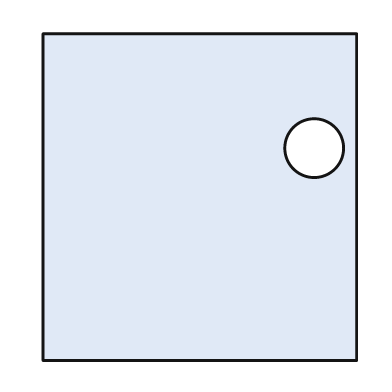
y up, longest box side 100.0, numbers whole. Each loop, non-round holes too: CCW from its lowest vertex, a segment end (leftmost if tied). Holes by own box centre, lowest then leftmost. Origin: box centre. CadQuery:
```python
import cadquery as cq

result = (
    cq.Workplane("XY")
    .moveTo(-48.0, -50.0)
    .lineTo(48.0, -50.0)
    .lineTo(48.0, 50.0)
    .lineTo(-48.0, 50.0)
    .close()
    .moveTo(35.0, 15.0)
    .circle(9.0)
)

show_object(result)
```